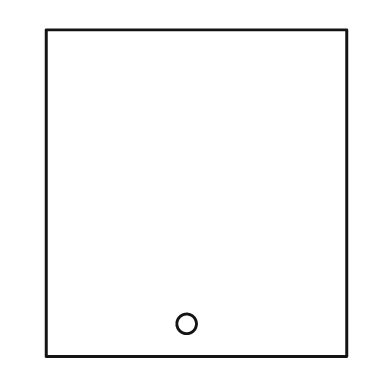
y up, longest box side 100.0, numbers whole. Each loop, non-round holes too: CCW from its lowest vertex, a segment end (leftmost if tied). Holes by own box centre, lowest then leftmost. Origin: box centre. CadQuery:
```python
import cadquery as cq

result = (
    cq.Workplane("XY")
    .moveTo(-46.0, -50.0)
    .lineTo(46.0, -50.0)
    .lineTo(46.0, 50.0)
    .lineTo(-46.0, 50.0)
    .close()
    .moveTo(-3.0, -40.0)
    .circle(3.0)
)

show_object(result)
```